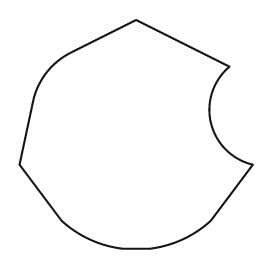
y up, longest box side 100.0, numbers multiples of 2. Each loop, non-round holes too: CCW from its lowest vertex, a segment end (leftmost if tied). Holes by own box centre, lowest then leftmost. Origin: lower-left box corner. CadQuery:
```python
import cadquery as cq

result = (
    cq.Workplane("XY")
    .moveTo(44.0, 0.0)
    .lineTo(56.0, 0.0)
    .threePointArc((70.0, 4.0), (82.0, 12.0))
    .lineTo(100.0, 36.0)
    .threePointArc((82.0, 54.0), (90.0, 78.0))
    .lineTo(50.0, 98.0)
    .lineTo(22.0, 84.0)
    .threePointArc((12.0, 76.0), (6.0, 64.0))
    .lineTo(0.0, 36.0)
    .lineTo(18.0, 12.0)
    .threePointArc((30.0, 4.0), (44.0, 0.0))
    .close()
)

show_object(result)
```